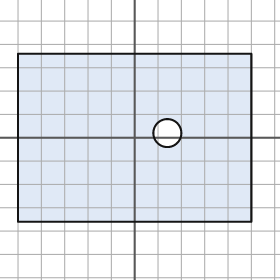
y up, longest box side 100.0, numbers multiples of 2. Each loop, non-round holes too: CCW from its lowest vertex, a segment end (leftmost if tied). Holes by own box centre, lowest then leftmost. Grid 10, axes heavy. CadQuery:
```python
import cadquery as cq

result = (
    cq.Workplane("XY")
    .moveTo(-50.0, -36.0)
    .lineTo(50.0, -36.0)
    .lineTo(50.0, 36.0)
    .lineTo(-50.0, 36.0)
    .close()
    .moveTo(14.0, 2.0)
    .circle(6.0)
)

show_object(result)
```